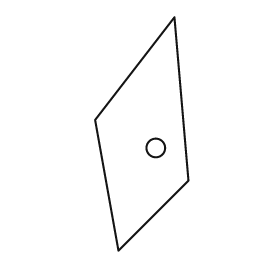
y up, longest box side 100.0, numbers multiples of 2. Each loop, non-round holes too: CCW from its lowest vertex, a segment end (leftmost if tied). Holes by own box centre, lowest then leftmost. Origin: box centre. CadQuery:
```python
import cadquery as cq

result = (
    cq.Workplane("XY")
    .moveTo(-10.0, -50.0)
    .lineTo(20.0, -20.0)
    .lineTo(14.0, 50.0)
    .lineTo(-20.0, 6.0)
    .close()
    .moveTo(6.0, -6.0)
    .circle(4.0)
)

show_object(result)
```